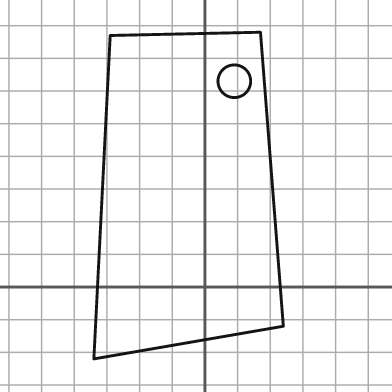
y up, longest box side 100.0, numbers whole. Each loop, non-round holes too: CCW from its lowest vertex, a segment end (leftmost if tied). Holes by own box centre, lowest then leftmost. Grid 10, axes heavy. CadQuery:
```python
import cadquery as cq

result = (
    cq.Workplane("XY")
    .moveTo(-34.0, -22.0)
    .lineTo(24.0, -12.0)
    .lineTo(17.0, 78.0)
    .lineTo(-29.0, 77.0)
    .close()
    .moveTo(9.0, 63.0)
    .circle(5.0)
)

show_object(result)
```